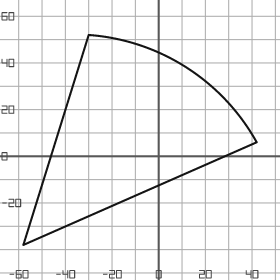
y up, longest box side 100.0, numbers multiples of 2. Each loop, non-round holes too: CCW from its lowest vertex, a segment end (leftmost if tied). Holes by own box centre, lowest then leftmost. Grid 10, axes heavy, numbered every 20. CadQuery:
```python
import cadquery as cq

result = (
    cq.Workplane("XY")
    .moveTo(-58.0, -38.0)
    .lineTo(42.0, 6.0)
    .threePointArc((12.0, 38.0), (-30.0, 52.0))
    .close()
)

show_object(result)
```